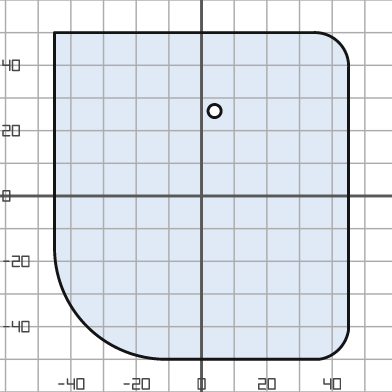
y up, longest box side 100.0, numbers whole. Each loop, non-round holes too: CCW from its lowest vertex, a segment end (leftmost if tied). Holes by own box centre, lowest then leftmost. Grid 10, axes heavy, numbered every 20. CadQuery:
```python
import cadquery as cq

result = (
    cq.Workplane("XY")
    .moveTo(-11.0, -50.0)
    .lineTo(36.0, -50.0)
    .threePointArc((42.0, -47.0), (45.0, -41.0))
    .lineTo(45.0, 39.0)
    .threePointArc((42.0, 47.0), (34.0, 50.0))
    .lineTo(-45.0, 50.0)
    .lineTo(-45.0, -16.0)
    .threePointArc((-35.0, -40.0), (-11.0, -50.0))
    .close()
    .moveTo(4.0, 26.0)
    .circle(2.0)
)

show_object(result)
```